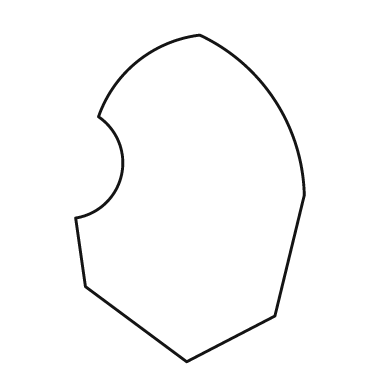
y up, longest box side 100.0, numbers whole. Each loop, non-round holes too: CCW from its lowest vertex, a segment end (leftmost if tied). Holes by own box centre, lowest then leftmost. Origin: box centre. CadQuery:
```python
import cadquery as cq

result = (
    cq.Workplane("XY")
    .moveTo(-1.0, -50.0)
    .lineTo(26.0, -36.0)
    .lineTo(35.0, 1.0)
    .threePointArc((26.0, 30.0), (3.0, 50.0))
    .threePointArc((-16.0, 42.0), (-28.0, 25.0))
    .threePointArc((-21.0, 7.0), (-35.0, -6.0))
    .lineTo(-32.0, -27.0)
    .close()
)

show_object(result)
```